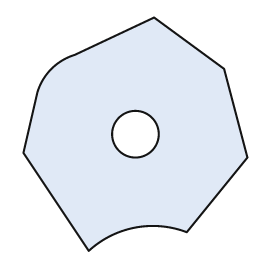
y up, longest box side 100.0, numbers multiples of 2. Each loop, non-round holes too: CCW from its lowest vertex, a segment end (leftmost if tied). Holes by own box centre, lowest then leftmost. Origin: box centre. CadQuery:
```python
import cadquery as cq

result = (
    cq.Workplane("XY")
    .moveTo(-20.0, -50.0)
    .threePointArc((0.0, -40.0), (22.0, -42.0))
    .lineTo(48.0, -10.0)
    .lineTo(38.0, 28.0)
    .lineTo(8.0, 50.0)
    .lineTo(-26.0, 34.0)
    .threePointArc((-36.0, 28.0), (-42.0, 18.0))
    .lineTo(-48.0, -8.0)
    .close()
    .moveTo(0.0, 0.0)
    .circle(10.0)
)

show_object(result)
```